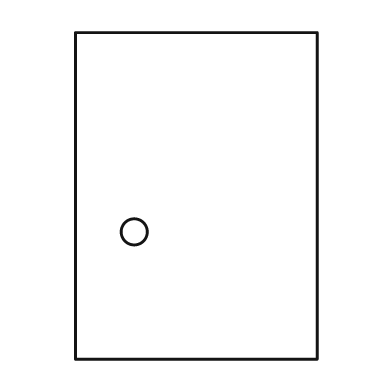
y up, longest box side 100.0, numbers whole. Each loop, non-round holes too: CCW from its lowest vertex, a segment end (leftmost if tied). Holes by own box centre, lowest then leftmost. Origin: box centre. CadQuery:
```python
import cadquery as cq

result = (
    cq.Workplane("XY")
    .moveTo(-37.0, -50.0)
    .lineTo(37.0, -50.0)
    .lineTo(37.0, 50.0)
    .lineTo(-37.0, 50.0)
    .close()
    .moveTo(-19.0, -11.0)
    .circle(4.0)
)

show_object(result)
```